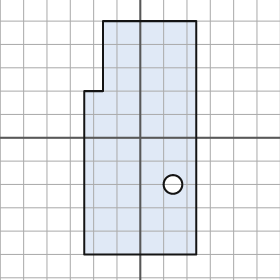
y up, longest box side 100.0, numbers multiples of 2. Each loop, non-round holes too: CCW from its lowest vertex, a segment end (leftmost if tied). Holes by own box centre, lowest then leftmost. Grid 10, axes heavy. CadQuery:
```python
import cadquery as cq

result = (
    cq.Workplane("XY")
    .moveTo(-24.0, -50.0)
    .lineTo(24.0, -50.0)
    .lineTo(24.0, 50.0)
    .lineTo(-16.0, 50.0)
    .lineTo(-16.0, 20.0)
    .lineTo(-24.0, 20.0)
    .close()
    .moveTo(14.0, -20.0)
    .circle(4.0)
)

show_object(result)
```